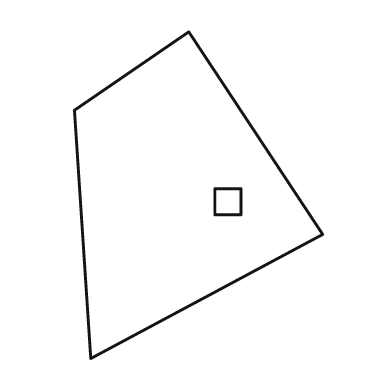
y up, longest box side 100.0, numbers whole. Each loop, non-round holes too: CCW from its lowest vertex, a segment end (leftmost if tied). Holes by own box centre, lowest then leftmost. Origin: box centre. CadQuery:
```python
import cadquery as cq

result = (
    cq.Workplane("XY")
    .moveTo(-33.0, -50.0)
    .lineTo(38.0, -12.0)
    .lineTo(-3.0, 50.0)
    .lineTo(-38.0, 26.0)
    .close()
    .moveTo(5.0, -6.0)
    .lineTo(13.0, -6.0)
    .lineTo(13.0, 2.0)
    .lineTo(5.0, 2.0)
    .close()
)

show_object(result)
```